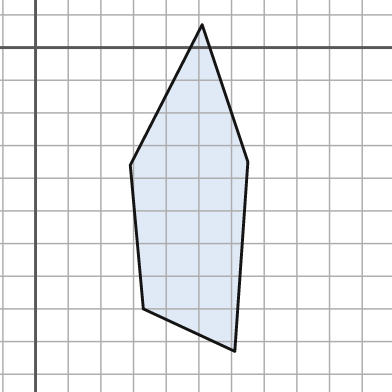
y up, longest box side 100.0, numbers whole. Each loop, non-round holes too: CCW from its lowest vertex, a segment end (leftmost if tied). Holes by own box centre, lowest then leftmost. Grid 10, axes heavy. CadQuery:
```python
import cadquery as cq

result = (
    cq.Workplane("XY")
    .moveTo(61.0, -93.0)
    .lineTo(65.0, -35.0)
    .lineTo(51.0, 7.0)
    .lineTo(29.0, -36.0)
    .lineTo(33.0, -80.0)
    .close()
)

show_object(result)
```